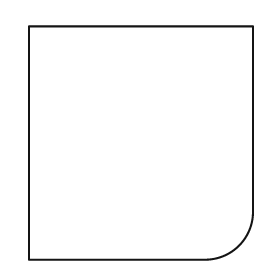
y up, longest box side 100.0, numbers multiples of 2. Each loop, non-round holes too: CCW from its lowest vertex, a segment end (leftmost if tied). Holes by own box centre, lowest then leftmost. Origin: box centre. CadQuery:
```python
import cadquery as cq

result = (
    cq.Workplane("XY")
    .moveTo(-48.0, -50.0)
    .lineTo(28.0, -50.0)
    .threePointArc((42.0, -44.0), (48.0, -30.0))
    .lineTo(48.0, 50.0)
    .lineTo(-48.0, 50.0)
    .close()
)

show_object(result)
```